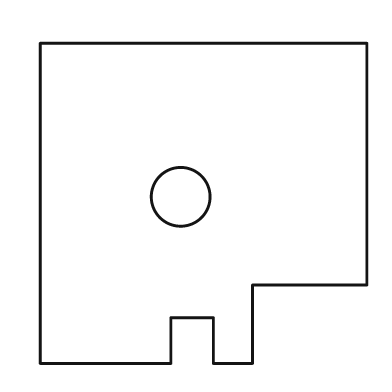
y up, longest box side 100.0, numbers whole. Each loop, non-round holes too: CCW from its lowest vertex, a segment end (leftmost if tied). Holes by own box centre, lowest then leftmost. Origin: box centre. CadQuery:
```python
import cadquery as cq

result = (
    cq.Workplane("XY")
    .moveTo(-50.0, -49.0)
    .lineTo(-10.0, -49.0)
    .lineTo(-10.0, -35.0)
    .lineTo(3.0, -35.0)
    .lineTo(3.0, -49.0)
    .lineTo(15.0, -49.0)
    .lineTo(15.0, -25.0)
    .lineTo(50.0, -25.0)
    .lineTo(50.0, 49.0)
    .lineTo(-50.0, 49.0)
    .close()
    .moveTo(-7.0, 2.0)
    .circle(9.0)
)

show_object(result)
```